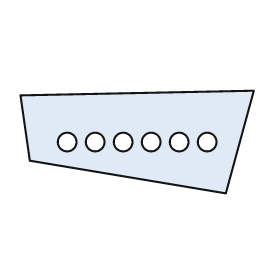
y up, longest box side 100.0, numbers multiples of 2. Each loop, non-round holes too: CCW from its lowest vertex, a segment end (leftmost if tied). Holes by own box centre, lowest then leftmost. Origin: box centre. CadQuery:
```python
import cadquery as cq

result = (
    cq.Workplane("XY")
    .moveTo(38.0, -22.0)
    .lineTo(50.0, 22.0)
    .lineTo(-50.0, 20.0)
    .lineTo(-46.0, -8.0)
    .close()
    .moveTo(-30.0, 0.0)
    .circle(4.0)
    .moveTo(-18.0, 0.0)
    .circle(4.0)
    .moveTo(-6.0, 0.0)
    .circle(4.0)
    .moveTo(6.0, 0.0)
    .circle(4.0)
    .moveTo(18.0, 0.0)
    .circle(4.0)
    .moveTo(30.0, 0.0)
    .circle(4.0)
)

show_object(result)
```